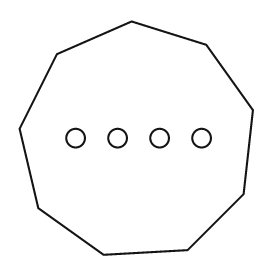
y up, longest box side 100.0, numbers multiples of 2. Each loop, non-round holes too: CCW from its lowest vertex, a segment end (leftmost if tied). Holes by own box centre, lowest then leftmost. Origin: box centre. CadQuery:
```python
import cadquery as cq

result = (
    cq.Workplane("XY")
    .moveTo(-14.0, -50.0)
    .lineTo(22.0, -48.0)
    .lineTo(46.0, -24.0)
    .lineTo(50.0, 12.0)
    .lineTo(30.0, 40.0)
    .lineTo(-2.0, 50.0)
    .lineTo(-34.0, 36.0)
    .lineTo(-50.0, 4.0)
    .lineTo(-42.0, -30.0)
    .close()
    .moveTo(-26.0, 0.0)
    .circle(4.0)
    .moveTo(-8.0, 0.0)
    .circle(4.0)
    .moveTo(10.0, 0.0)
    .circle(4.0)
    .moveTo(28.0, 0.0)
    .circle(4.0)
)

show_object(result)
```